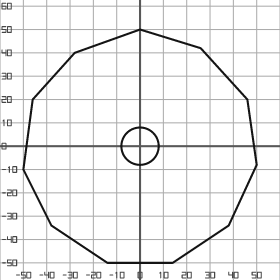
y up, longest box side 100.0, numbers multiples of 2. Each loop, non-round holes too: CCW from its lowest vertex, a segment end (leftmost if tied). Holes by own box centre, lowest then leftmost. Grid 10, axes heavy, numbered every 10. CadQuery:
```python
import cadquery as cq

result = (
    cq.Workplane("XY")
    .moveTo(-14.0, -50.0)
    .lineTo(14.0, -50.0)
    .lineTo(38.0, -34.0)
    .lineTo(50.0, -8.0)
    .lineTo(46.0, 20.0)
    .lineTo(26.0, 42.0)
    .lineTo(0.0, 50.0)
    .lineTo(-28.0, 40.0)
    .lineTo(-46.0, 20.0)
    .lineTo(-50.0, -10.0)
    .lineTo(-38.0, -34.0)
    .close()
    .moveTo(0.0, 0.0)
    .circle(8.0)
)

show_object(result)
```